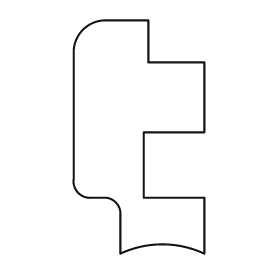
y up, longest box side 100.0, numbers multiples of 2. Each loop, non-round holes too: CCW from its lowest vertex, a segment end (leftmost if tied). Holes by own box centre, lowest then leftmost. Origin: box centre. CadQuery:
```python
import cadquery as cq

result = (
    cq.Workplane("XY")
    .moveTo(-8.0, -50.0)
    .threePointArc((10.0, -46.0), (28.0, -50.0))
    .lineTo(28.0, -26.0)
    .lineTo(2.0, -26.0)
    .lineTo(2.0, 2.0)
    .lineTo(28.0, 2.0)
    .lineTo(28.0, 32.0)
    .lineTo(4.0, 32.0)
    .lineTo(4.0, 50.0)
    .lineTo(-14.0, 50.0)
    .threePointArc((-24.0, 46.0), (-28.0, 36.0))
    .lineTo(-28.0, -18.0)
    .threePointArc((-26.0, -24.0), (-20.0, -26.0))
    .lineTo(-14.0, -26.0)
    .threePointArc((-10.0, -28.0), (-8.0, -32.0))
    .close()
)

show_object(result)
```